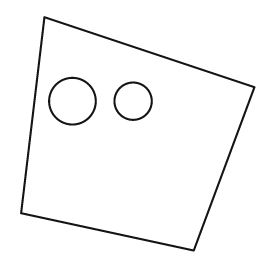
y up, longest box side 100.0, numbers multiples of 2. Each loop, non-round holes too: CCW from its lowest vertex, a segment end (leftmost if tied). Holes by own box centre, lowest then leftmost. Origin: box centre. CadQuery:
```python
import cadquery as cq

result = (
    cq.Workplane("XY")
    .moveTo(24.0, -50.0)
    .lineTo(50.0, 20.0)
    .lineTo(-40.0, 50.0)
    .lineTo(-50.0, -34.0)
    .close()
    .moveTo(-28.0, 14.0)
    .circle(10.0)
    .moveTo(-2.0, 14.0)
    .circle(8.0)
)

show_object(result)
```